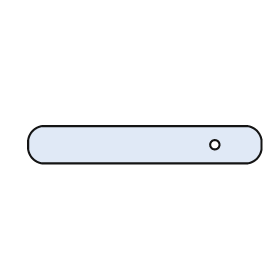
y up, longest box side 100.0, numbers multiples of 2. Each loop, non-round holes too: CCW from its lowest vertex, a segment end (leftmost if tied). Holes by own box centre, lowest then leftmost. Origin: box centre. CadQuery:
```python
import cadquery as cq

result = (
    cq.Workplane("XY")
    .moveTo(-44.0, -8.0)
    .lineTo(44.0, -8.0)
    .threePointArc((48.0, -6.0), (50.0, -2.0))
    .lineTo(50.0, 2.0)
    .threePointArc((48.0, 6.0), (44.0, 8.0))
    .lineTo(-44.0, 8.0)
    .threePointArc((-48.0, 6.0), (-50.0, 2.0))
    .lineTo(-50.0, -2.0)
    .threePointArc((-48.0, -6.0), (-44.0, -8.0))
    .close()
    .moveTo(30.0, 0.0)
    .circle(2.0)
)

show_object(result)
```